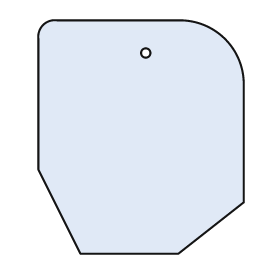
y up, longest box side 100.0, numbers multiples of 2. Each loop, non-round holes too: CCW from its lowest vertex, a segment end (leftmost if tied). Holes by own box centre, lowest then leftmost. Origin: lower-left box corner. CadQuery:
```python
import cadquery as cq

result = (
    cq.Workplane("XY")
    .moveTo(18.0, 0.0)
    .lineTo(60.0, 0.0)
    .lineTo(88.0, 22.0)
    .lineTo(88.0, 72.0)
    .threePointArc((80.0, 92.0), (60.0, 100.0))
    .lineTo(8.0, 100.0)
    .threePointArc((2.0, 98.0), (0.0, 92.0))
    .lineTo(0.0, 36.0)
    .close()
    .moveTo(46.0, 86.0)
    .circle(2.0)
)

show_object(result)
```